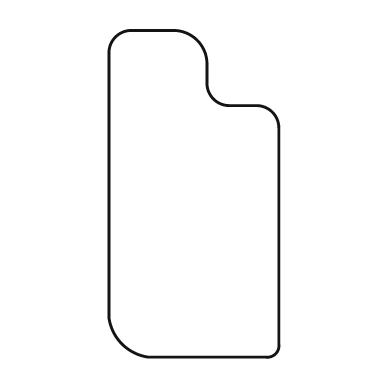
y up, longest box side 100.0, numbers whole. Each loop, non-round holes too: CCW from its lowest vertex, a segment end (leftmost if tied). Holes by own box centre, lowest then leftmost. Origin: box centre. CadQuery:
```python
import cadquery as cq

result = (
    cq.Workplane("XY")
    .moveTo(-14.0, -50.0)
    .lineTo(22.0, -50.0)
    .threePointArc((25.0, -49.0), (26.0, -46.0))
    .lineTo(26.0, 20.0)
    .threePointArc((24.0, 25.0), (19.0, 27.0))
    .lineTo(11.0, 27.0)
    .threePointArc((6.0, 29.0), (4.0, 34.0))
    .lineTo(4.0, 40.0)
    .threePointArc((1.0, 47.0), (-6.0, 50.0))
    .lineTo(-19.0, 50.0)
    .threePointArc((-24.0, 48.0), (-26.0, 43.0))
    .lineTo(-26.0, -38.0)
    .threePointArc((-22.0, -46.0), (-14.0, -50.0))
    .close()
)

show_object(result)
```